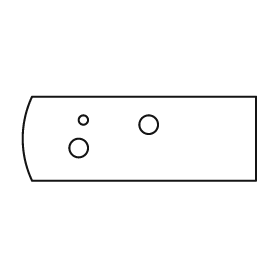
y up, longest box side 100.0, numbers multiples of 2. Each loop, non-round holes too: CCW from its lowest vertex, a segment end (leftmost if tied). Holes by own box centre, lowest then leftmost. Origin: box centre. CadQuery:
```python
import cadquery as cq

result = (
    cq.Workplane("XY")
    .moveTo(-46.0, -18.0)
    .lineTo(50.0, -18.0)
    .lineTo(50.0, 18.0)
    .lineTo(-46.0, 18.0)
    .threePointArc((-50.0, 0.0), (-46.0, -18.0))
    .close()
    .moveTo(-26.0, -4.0)
    .circle(4.0)
    .moveTo(4.0, 6.0)
    .circle(4.0)
    .moveTo(-24.0, 8.0)
    .circle(2.0)
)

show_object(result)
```